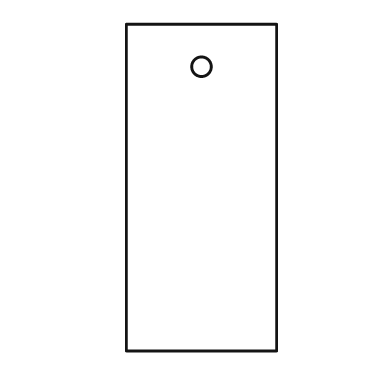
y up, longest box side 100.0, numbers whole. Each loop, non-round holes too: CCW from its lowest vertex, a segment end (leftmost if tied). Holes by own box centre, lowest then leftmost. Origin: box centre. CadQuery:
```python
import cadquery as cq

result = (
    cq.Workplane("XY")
    .moveTo(-23.0, -50.0)
    .lineTo(23.0, -50.0)
    .lineTo(23.0, 50.0)
    .lineTo(-23.0, 50.0)
    .close()
    .moveTo(0.0, 37.0)
    .circle(3.0)
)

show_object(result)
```